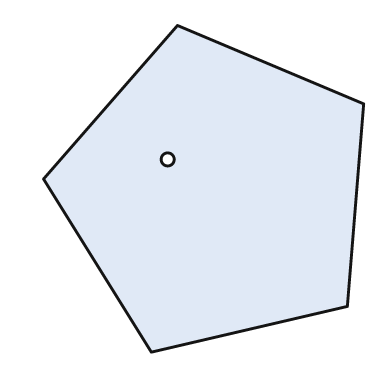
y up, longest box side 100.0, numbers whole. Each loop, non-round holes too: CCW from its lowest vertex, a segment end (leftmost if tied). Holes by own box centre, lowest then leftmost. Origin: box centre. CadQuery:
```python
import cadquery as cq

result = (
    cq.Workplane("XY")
    .moveTo(-16.0, -50.0)
    .lineTo(44.0, -36.0)
    .lineTo(49.0, 26.0)
    .lineTo(-8.0, 50.0)
    .lineTo(-49.0, 3.0)
    .close()
    .moveTo(-11.0, 9.0)
    .circle(2.0)
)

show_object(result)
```